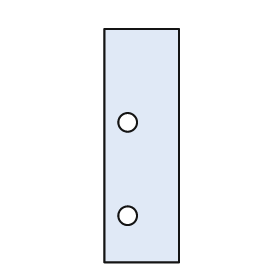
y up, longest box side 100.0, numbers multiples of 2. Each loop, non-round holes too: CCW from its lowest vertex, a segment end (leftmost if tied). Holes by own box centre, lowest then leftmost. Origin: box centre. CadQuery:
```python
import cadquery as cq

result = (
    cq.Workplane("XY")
    .moveTo(-16.0, -50.0)
    .lineTo(16.0, -50.0)
    .lineTo(16.0, 50.0)
    .lineTo(-16.0, 50.0)
    .close()
    .moveTo(-6.0, -30.0)
    .circle(4.0)
    .moveTo(-6.0, 10.0)
    .circle(4.0)
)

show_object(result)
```